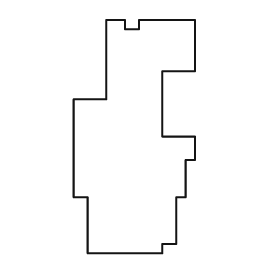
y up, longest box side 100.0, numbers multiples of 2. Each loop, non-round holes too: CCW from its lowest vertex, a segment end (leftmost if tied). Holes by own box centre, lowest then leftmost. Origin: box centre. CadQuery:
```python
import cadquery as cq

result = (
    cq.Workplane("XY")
    .moveTo(-20.0, -50.0)
    .lineTo(12.0, -50.0)
    .lineTo(12.0, -46.0)
    .lineTo(18.0, -46.0)
    .lineTo(18.0, -26.0)
    .lineTo(22.0, -26.0)
    .lineTo(22.0, -10.0)
    .lineTo(26.0, -10.0)
    .lineTo(26.0, 0.0)
    .lineTo(12.0, 0.0)
    .lineTo(12.0, 28.0)
    .lineTo(26.0, 28.0)
    .lineTo(26.0, 50.0)
    .lineTo(2.0, 50.0)
    .lineTo(2.0, 46.0)
    .lineTo(-4.0, 46.0)
    .lineTo(-4.0, 50.0)
    .lineTo(-12.0, 50.0)
    .lineTo(-12.0, 16.0)
    .lineTo(-26.0, 16.0)
    .lineTo(-26.0, -26.0)
    .lineTo(-20.0, -26.0)
    .close()
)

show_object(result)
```